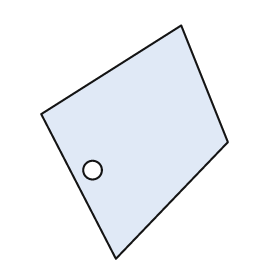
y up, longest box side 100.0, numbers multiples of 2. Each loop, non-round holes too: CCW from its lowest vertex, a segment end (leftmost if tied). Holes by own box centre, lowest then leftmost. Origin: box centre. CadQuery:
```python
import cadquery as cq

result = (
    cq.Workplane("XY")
    .moveTo(-8.0, -50.0)
    .lineTo(40.0, 0.0)
    .lineTo(20.0, 50.0)
    .lineTo(-40.0, 12.0)
    .close()
    .moveTo(-18.0, -12.0)
    .circle(4.0)
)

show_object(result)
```